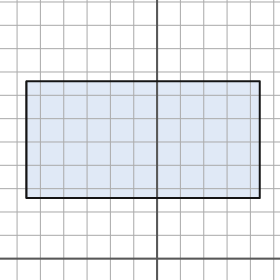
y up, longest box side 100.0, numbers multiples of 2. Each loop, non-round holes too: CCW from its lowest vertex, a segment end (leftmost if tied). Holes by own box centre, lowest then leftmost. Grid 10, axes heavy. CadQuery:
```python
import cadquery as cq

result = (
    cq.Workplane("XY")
    .moveTo(-56.0, 26.0)
    .lineTo(44.0, 26.0)
    .lineTo(44.0, 76.0)
    .lineTo(-56.0, 76.0)
    .close()
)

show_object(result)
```